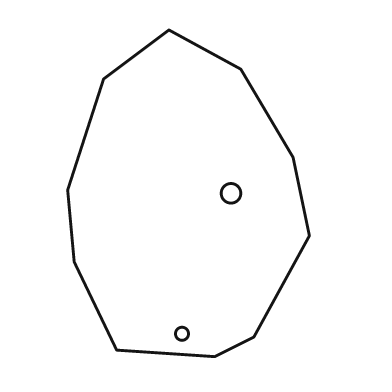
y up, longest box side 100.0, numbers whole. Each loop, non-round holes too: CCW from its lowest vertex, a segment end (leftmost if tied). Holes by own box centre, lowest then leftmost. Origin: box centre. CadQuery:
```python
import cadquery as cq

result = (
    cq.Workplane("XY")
    .moveTo(8.0, -50.0)
    .lineTo(20.0, -44.0)
    .lineTo(37.0, -13.0)
    .lineTo(32.0, 11.0)
    .lineTo(16.0, 38.0)
    .lineTo(-6.0, 50.0)
    .lineTo(-26.0, 35.0)
    .lineTo(-37.0, 1.0)
    .lineTo(-35.0, -21.0)
    .lineTo(-22.0, -48.0)
    .close()
    .moveTo(-2.0, -43.0)
    .circle(2.0)
    .moveTo(13.0, 0.0)
    .circle(3.0)
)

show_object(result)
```